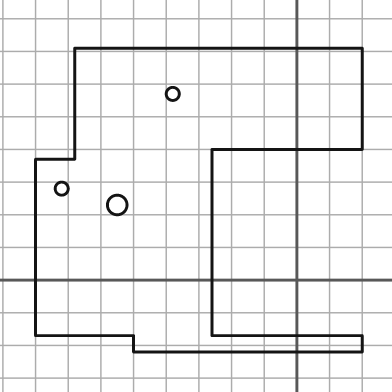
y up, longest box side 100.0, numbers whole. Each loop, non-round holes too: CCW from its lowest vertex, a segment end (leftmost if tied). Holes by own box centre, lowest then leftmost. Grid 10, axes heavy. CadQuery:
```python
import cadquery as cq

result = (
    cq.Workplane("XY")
    .moveTo(-50.0, -22.0)
    .lineTo(20.0, -22.0)
    .lineTo(20.0, -17.0)
    .lineTo(-26.0, -17.0)
    .lineTo(-26.0, 40.0)
    .lineTo(20.0, 40.0)
    .lineTo(20.0, 71.0)
    .lineTo(-68.0, 71.0)
    .lineTo(-68.0, 37.0)
    .lineTo(-80.0, 37.0)
    .lineTo(-80.0, -17.0)
    .lineTo(-50.0, -17.0)
    .close()
    .moveTo(-55.0, 23.0)
    .circle(3.0)
    .moveTo(-72.0, 28.0)
    .circle(2.0)
    .moveTo(-38.0, 57.0)
    .circle(2.0)
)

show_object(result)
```